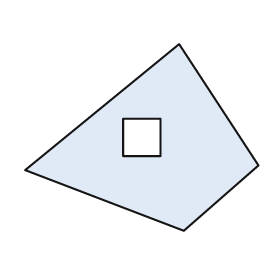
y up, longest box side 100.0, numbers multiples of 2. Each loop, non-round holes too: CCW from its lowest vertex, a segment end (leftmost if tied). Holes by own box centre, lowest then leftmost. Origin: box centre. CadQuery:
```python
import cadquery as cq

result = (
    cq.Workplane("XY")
    .moveTo(18.0, -40.0)
    .lineTo(50.0, -12.0)
    .lineTo(16.0, 40.0)
    .lineTo(-50.0, -14.0)
    .close()
    .moveTo(-8.0, -8.0)
    .lineTo(8.0, -8.0)
    .lineTo(8.0, 8.0)
    .lineTo(-8.0, 8.0)
    .close()
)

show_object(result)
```